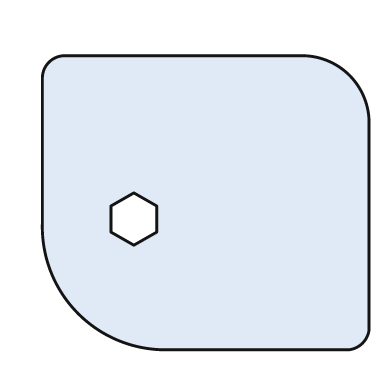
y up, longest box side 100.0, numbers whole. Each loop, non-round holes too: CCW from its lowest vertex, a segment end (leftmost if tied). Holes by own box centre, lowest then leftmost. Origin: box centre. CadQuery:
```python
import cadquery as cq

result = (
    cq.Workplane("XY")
    .moveTo(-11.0, -45.0)
    .lineTo(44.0, -45.0)
    .threePointArc((48.0, -43.0), (50.0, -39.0))
    .lineTo(50.0, 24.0)
    .threePointArc((44.0, 39.0), (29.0, 45.0))
    .lineTo(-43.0, 45.0)
    .threePointArc((-48.0, 43.0), (-50.0, 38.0))
    .lineTo(-50.0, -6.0)
    .threePointArc((-39.0, -34.0), (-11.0, -45.0))
    .close()
    .moveTo(-22.0, -13.0)
    .lineTo(-15.0, -9.0)
    .lineTo(-15.0, -1.0)
    .lineTo(-22.0, 3.0)
    .lineTo(-29.0, -1.0)
    .lineTo(-29.0, -9.0)
    .close()
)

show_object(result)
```